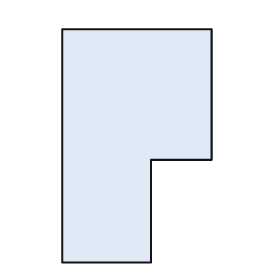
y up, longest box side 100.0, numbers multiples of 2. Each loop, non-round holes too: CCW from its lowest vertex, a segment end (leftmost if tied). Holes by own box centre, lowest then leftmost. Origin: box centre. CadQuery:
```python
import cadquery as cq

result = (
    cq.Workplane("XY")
    .moveTo(-32.0, -50.0)
    .lineTo(6.0, -50.0)
    .lineTo(6.0, -6.0)
    .lineTo(32.0, -6.0)
    .lineTo(32.0, 50.0)
    .lineTo(-32.0, 50.0)
    .close()
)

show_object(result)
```